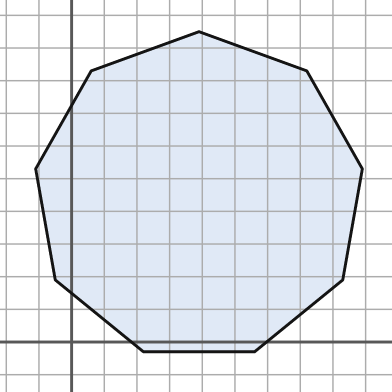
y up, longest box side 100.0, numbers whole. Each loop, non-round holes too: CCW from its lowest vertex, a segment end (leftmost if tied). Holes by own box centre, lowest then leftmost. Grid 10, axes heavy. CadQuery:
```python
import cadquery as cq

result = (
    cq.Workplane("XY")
    .moveTo(22.0, -3.0)
    .lineTo(56.0, -3.0)
    .lineTo(83.0, 19.0)
    .lineTo(89.0, 53.0)
    .lineTo(72.0, 83.0)
    .lineTo(39.0, 95.0)
    .lineTo(6.0, 83.0)
    .lineTo(-11.0, 53.0)
    .lineTo(-5.0, 19.0)
    .close()
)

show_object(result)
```